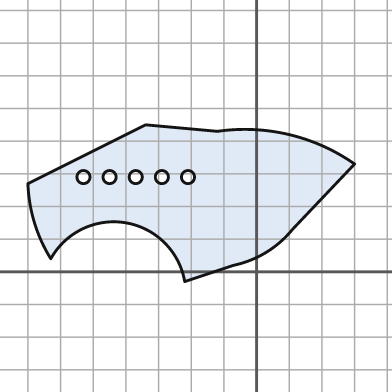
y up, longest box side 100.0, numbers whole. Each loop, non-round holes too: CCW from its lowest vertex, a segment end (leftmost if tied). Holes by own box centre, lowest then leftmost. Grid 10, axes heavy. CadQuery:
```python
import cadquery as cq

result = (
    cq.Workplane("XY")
    .moveTo(-22.0, -3.0)
    .lineTo(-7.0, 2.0)
    .threePointArc((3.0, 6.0), (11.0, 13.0))
    .lineTo(30.0, 33.0)
    .threePointArc((10.0, 42.0), (-12.0, 43.0))
    .lineTo(-34.0, 45.0)
    .lineTo(-70.0, 27.0)
    .threePointArc((-68.0, 15.0), (-63.0, 4.0))
    .threePointArc((-40.0, 15.0), (-22.0, -3.0))
    .close()
    .moveTo(-53.0, 29.0)
    .circle(2.0)
    .moveTo(-45.0, 29.0)
    .circle(2.0)
    .moveTo(-37.0, 29.0)
    .circle(2.0)
    .moveTo(-29.0, 29.0)
    .circle(2.0)
    .moveTo(-21.0, 29.0)
    .circle(2.0)
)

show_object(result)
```